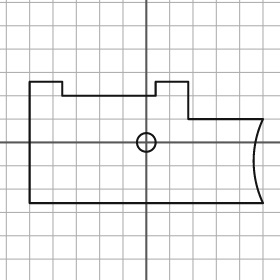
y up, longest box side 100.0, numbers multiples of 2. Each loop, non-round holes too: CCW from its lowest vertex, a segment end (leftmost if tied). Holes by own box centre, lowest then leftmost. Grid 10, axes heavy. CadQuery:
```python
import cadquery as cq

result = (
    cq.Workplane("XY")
    .moveTo(-50.0, -26.0)
    .lineTo(50.0, -26.0)
    .threePointArc((46.0, -8.0), (50.0, 10.0))
    .lineTo(18.0, 10.0)
    .lineTo(18.0, 26.0)
    .lineTo(4.0, 26.0)
    .lineTo(4.0, 20.0)
    .lineTo(-36.0, 20.0)
    .lineTo(-36.0, 26.0)
    .lineTo(-50.0, 26.0)
    .close()
    .moveTo(0.0, 0.0)
    .circle(4.0)
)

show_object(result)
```